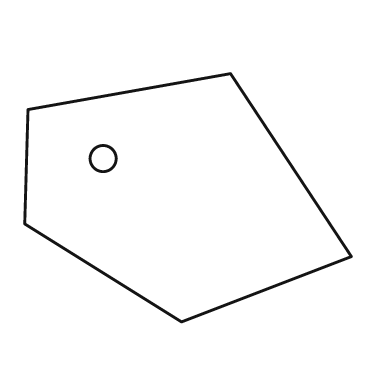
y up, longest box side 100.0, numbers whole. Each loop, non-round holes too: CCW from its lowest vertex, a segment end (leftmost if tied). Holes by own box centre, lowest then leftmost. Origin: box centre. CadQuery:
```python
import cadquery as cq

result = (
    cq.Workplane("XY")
    .moveTo(-2.0, -38.0)
    .lineTo(50.0, -18.0)
    .lineTo(13.0, 38.0)
    .lineTo(-49.0, 27.0)
    .lineTo(-50.0, -8.0)
    .close()
    .moveTo(-26.0, 12.0)
    .circle(4.0)
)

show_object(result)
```